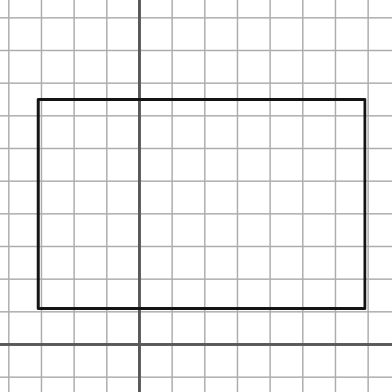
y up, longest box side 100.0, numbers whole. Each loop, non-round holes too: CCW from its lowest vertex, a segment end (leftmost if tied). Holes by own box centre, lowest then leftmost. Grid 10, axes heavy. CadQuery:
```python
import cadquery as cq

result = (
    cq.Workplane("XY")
    .moveTo(-31.0, 11.0)
    .lineTo(69.0, 11.0)
    .lineTo(69.0, 75.0)
    .lineTo(-31.0, 75.0)
    .close()
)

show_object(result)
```